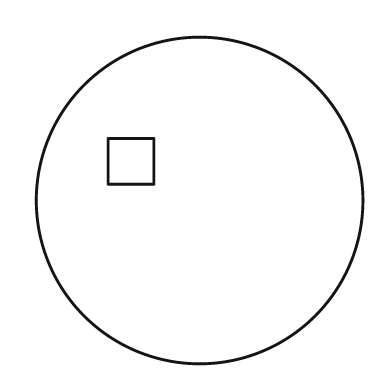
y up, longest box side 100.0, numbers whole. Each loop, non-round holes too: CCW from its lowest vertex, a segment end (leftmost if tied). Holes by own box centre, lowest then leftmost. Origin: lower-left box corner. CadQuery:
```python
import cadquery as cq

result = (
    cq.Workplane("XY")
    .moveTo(50.0, 50.0)
    .circle(50.0)
    .moveTo(22.0, 55.0)
    .lineTo(36.0, 55.0)
    .lineTo(36.0, 69.0)
    .lineTo(22.0, 69.0)
    .close()
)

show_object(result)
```